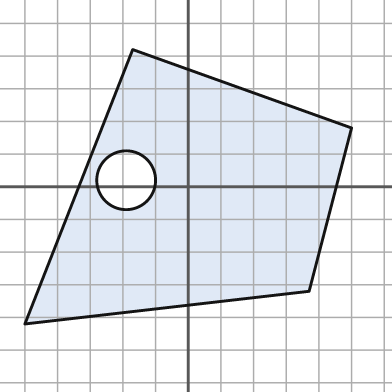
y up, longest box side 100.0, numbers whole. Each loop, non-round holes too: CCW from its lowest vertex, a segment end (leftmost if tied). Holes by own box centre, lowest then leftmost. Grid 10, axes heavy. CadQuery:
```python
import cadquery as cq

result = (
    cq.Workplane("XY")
    .moveTo(-50.0, -42.0)
    .lineTo(37.0, -32.0)
    .lineTo(50.0, 18.0)
    .lineTo(-17.0, 42.0)
    .close()
    .moveTo(-19.0, 2.0)
    .circle(9.0)
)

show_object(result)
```